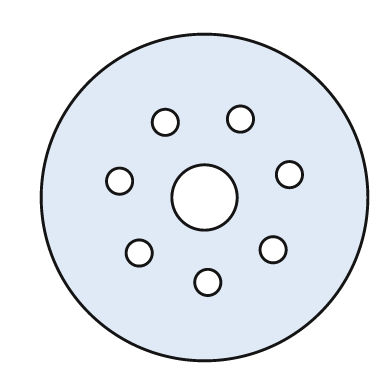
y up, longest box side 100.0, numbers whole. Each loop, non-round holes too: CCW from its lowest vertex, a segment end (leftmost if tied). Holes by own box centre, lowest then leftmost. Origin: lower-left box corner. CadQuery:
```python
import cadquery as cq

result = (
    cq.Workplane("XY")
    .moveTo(50.0, 50.0)
    .circle(50.0)
    .moveTo(51.0, 24.0)
    .circle(4.0)
    .moveTo(30.0, 33.0)
    .circle(4.0)
    .moveTo(71.0, 34.0)
    .circle(4.0)
    .moveTo(50.0, 50.0)
    .circle(10.0)
    .moveTo(24.0, 55.0)
    .circle(4.0)
    .moveTo(76.0, 57.0)
    .circle(4.0)
    .moveTo(38.0, 73.0)
    .circle(4.0)
    .moveTo(61.0, 74.0)
    .circle(4.0)
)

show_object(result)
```